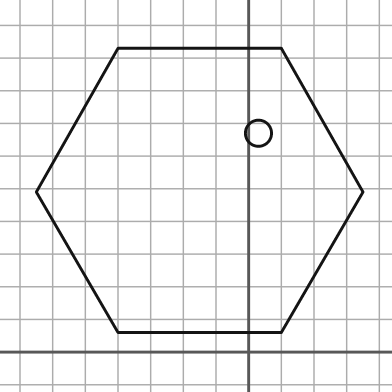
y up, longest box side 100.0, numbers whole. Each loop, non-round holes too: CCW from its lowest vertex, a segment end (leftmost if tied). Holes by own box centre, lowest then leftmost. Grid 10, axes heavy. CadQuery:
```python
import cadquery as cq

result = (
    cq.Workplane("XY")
    .moveTo(-40.0, 6.0)
    .lineTo(10.0, 6.0)
    .lineTo(35.0, 49.0)
    .lineTo(10.0, 93.0)
    .lineTo(-40.0, 93.0)
    .lineTo(-65.0, 49.0)
    .close()
    .moveTo(3.0, 67.0)
    .circle(4.0)
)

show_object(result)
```